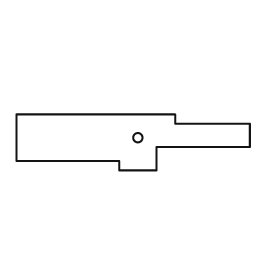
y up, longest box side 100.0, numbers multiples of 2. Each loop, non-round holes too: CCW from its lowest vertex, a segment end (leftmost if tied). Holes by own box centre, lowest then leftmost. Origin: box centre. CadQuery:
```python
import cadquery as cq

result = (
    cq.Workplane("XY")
    .moveTo(-6.0, -12.0)
    .lineTo(10.0, -12.0)
    .lineTo(10.0, -2.0)
    .lineTo(50.0, -2.0)
    .lineTo(50.0, 8.0)
    .lineTo(18.0, 8.0)
    .lineTo(18.0, 12.0)
    .lineTo(-50.0, 12.0)
    .lineTo(-50.0, -8.0)
    .lineTo(-6.0, -8.0)
    .close()
    .moveTo(2.0, 2.0)
    .circle(2.0)
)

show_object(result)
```